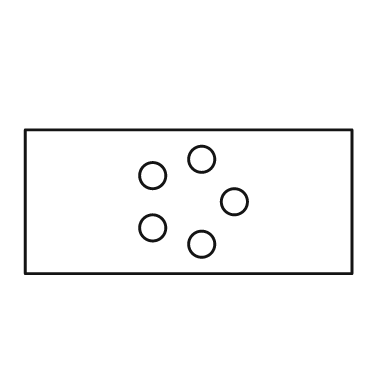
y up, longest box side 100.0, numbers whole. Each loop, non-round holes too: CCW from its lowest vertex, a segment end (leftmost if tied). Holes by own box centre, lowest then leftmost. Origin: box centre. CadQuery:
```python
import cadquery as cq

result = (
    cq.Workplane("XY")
    .moveTo(-50.0, -22.0)
    .lineTo(50.0, -22.0)
    .lineTo(50.0, 22.0)
    .lineTo(-50.0, 22.0)
    .close()
    .moveTo(4.0, -13.0)
    .circle(4.0)
    .moveTo(-11.0, -8.0)
    .circle(4.0)
    .moveTo(14.0, 0.0)
    .circle(4.0)
    .moveTo(-11.0, 8.0)
    .circle(4.0)
    .moveTo(4.0, 13.0)
    .circle(4.0)
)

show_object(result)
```